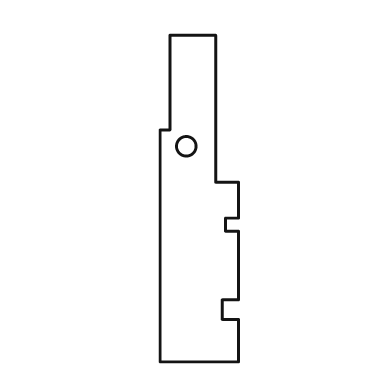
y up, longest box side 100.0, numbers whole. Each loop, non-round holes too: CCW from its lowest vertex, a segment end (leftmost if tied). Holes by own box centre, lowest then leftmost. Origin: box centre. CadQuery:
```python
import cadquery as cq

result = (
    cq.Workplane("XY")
    .moveTo(-12.0, -50.0)
    .lineTo(12.0, -50.0)
    .lineTo(12.0, -37.0)
    .lineTo(7.0, -37.0)
    .lineTo(7.0, -31.0)
    .lineTo(12.0, -31.0)
    .lineTo(12.0, -10.0)
    .lineTo(8.0, -10.0)
    .lineTo(8.0, -6.0)
    .lineTo(12.0, -6.0)
    .lineTo(12.0, 5.0)
    .lineTo(5.0, 5.0)
    .lineTo(5.0, 50.0)
    .lineTo(-9.0, 50.0)
    .lineTo(-9.0, 21.0)
    .lineTo(-12.0, 21.0)
    .close()
    .moveTo(-4.0, 16.0)
    .circle(3.0)
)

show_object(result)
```